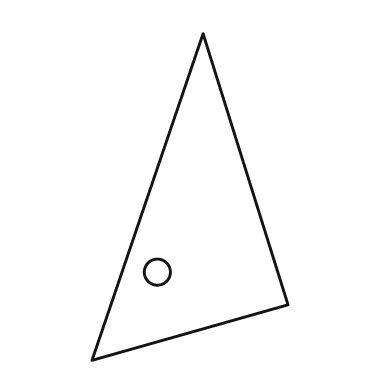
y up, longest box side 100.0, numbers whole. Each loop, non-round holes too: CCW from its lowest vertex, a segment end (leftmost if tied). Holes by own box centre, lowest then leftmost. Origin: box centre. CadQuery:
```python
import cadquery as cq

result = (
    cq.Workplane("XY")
    .moveTo(-30.0, -50.0)
    .lineTo(30.0, -33.0)
    .lineTo(4.0, 50.0)
    .close()
    .moveTo(-10.0, -23.0)
    .circle(4.0)
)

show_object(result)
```